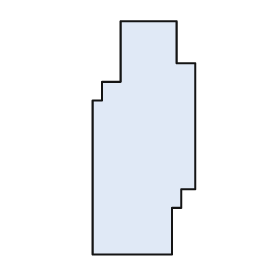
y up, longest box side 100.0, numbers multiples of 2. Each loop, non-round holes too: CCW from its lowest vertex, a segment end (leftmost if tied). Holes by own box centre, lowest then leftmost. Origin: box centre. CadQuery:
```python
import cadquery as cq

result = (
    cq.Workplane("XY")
    .moveTo(-22.0, -50.0)
    .lineTo(12.0, -50.0)
    .lineTo(12.0, -30.0)
    .lineTo(16.0, -30.0)
    .lineTo(16.0, -22.0)
    .lineTo(22.0, -22.0)
    .lineTo(22.0, 32.0)
    .lineTo(14.0, 32.0)
    .lineTo(14.0, 50.0)
    .lineTo(-10.0, 50.0)
    .lineTo(-10.0, 24.0)
    .lineTo(-18.0, 24.0)
    .lineTo(-18.0, 16.0)
    .lineTo(-22.0, 16.0)
    .close()
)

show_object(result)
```